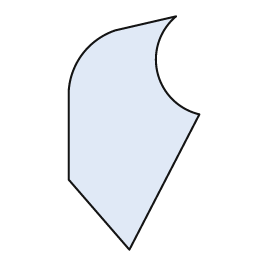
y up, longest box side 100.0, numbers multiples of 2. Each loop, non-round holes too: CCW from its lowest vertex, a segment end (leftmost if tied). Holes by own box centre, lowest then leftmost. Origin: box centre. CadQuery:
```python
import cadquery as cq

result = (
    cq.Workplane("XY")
    .moveTo(-2.0, -50.0)
    .lineTo(28.0, 8.0)
    .threePointArc((10.0, 26.0), (18.0, 50.0))
    .lineTo(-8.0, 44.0)
    .threePointArc((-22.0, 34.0), (-28.0, 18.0))
    .lineTo(-28.0, -20.0)
    .close()
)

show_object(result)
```